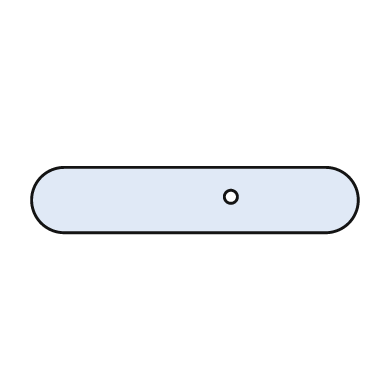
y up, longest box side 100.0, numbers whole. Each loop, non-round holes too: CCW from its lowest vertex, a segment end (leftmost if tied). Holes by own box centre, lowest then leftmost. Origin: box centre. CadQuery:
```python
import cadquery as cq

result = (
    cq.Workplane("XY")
    .moveTo(-40.0, -10.0)
    .lineTo(40.0, -10.0)
    .threePointArc((50.0, 0.0), (40.0, 10.0))
    .lineTo(-40.0, 10.0)
    .threePointArc((-50.0, 0.0), (-40.0, -10.0))
    .close()
    .moveTo(11.0, 1.0)
    .circle(2.0)
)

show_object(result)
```